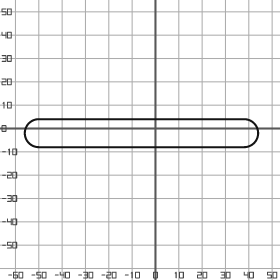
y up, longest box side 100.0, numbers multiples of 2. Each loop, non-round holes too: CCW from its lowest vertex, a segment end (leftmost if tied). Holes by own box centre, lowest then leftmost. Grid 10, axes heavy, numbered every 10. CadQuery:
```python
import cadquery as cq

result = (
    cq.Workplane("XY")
    .moveTo(-50.0, -8.0)
    .lineTo(38.0, -8.0)
    .threePointArc((44.0, -2.0), (38.0, 4.0))
    .lineTo(-50.0, 4.0)
    .threePointArc((-56.0, -2.0), (-50.0, -8.0))
    .close()
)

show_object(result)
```